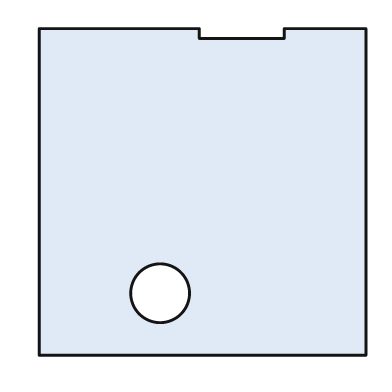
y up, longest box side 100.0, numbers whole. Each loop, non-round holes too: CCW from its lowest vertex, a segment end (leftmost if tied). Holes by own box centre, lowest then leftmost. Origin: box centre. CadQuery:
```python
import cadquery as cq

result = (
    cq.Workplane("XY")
    .moveTo(-50.0, -50.0)
    .lineTo(50.0, -50.0)
    .lineTo(50.0, 50.0)
    .lineTo(25.0, 50.0)
    .lineTo(25.0, 47.0)
    .lineTo(-1.0, 47.0)
    .lineTo(-1.0, 50.0)
    .lineTo(-50.0, 50.0)
    .close()
    .moveTo(-13.0, -31.0)
    .circle(9.0)
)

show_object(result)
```